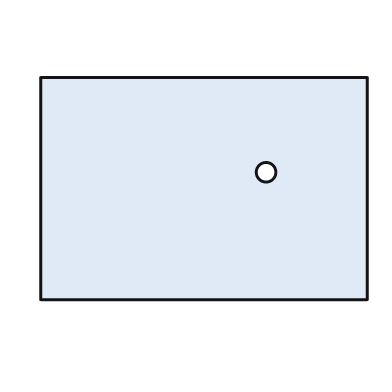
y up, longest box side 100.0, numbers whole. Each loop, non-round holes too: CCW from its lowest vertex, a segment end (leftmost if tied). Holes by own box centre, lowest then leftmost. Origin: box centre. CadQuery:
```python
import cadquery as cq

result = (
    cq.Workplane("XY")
    .moveTo(-50.0, -34.0)
    .lineTo(50.0, -34.0)
    .lineTo(50.0, 34.0)
    .lineTo(-50.0, 34.0)
    .close()
    .moveTo(19.0, 5.0)
    .circle(3.0)
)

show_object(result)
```